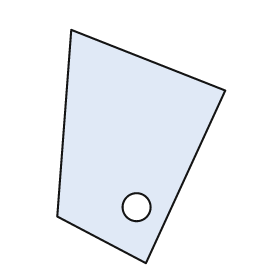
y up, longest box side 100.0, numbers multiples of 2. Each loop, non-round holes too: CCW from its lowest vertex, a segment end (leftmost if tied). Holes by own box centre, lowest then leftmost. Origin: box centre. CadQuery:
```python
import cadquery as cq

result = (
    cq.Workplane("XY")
    .moveTo(2.0, -50.0)
    .lineTo(36.0, 24.0)
    .lineTo(-30.0, 50.0)
    .lineTo(-36.0, -30.0)
    .close()
    .moveTo(-2.0, -26.0)
    .circle(6.0)
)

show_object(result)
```